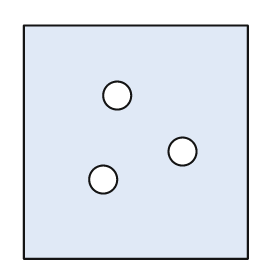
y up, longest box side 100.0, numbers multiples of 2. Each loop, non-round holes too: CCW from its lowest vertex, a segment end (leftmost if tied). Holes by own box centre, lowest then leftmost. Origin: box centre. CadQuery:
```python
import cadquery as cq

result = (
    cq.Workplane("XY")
    .moveTo(-48.0, -50.0)
    .lineTo(48.0, -50.0)
    .lineTo(48.0, 50.0)
    .lineTo(-48.0, 50.0)
    .close()
    .moveTo(-14.0, -16.0)
    .circle(6.0)
    .moveTo(20.0, -4.0)
    .circle(6.0)
    .moveTo(-8.0, 20.0)
    .circle(6.0)
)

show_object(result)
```